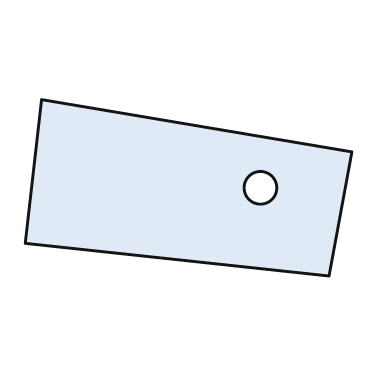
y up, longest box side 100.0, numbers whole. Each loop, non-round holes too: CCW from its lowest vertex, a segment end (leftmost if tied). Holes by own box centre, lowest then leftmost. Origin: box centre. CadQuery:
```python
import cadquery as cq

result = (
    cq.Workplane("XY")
    .moveTo(43.0, -27.0)
    .lineTo(50.0, 11.0)
    .lineTo(-45.0, 27.0)
    .lineTo(-50.0, -17.0)
    .close()
    .moveTo(22.0, 0.0)
    .circle(5.0)
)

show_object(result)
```